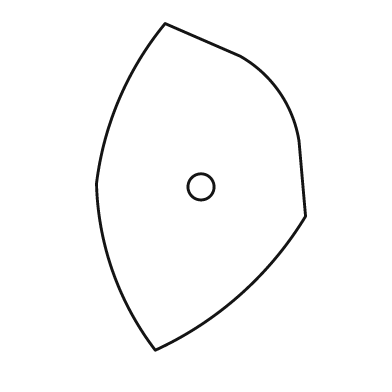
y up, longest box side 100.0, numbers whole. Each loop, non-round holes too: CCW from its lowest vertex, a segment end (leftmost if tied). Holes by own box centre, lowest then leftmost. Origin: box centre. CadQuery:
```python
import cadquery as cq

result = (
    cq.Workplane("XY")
    .moveTo(-14.0, -50.0)
    .threePointArc((12.0, -33.0), (32.0, -9.0))
    .lineTo(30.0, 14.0)
    .threePointArc((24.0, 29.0), (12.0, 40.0))
    .lineTo(-11.0, 50.0)
    .threePointArc((-25.0, 27.0), (-32.0, 1.0))
    .threePointArc((-27.0, -26.0), (-14.0, -50.0))
    .close()
    .moveTo(0.0, 0.0)
    .circle(4.0)
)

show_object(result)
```